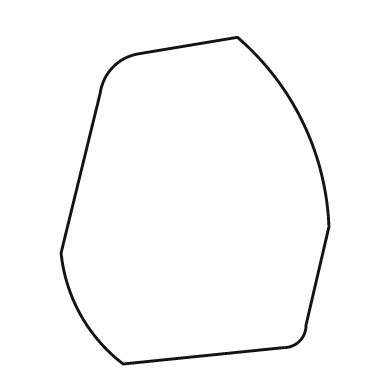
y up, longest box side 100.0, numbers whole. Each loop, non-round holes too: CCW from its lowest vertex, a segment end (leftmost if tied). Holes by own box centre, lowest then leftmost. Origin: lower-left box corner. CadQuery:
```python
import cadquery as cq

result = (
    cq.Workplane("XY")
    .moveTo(19.0, 0.0)
    .lineTo(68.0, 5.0)
    .threePointArc((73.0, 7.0), (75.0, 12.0))
    .lineTo(82.0, 42.0)
    .threePointArc((74.0, 74.0), (54.0, 100.0))
    .lineTo(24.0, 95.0)
    .threePointArc((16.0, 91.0), (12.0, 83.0))
    .lineTo(0.0, 34.0)
    .threePointArc((6.0, 15.0), (19.0, 0.0))
    .close()
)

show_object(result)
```